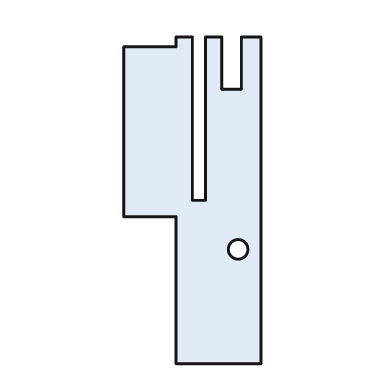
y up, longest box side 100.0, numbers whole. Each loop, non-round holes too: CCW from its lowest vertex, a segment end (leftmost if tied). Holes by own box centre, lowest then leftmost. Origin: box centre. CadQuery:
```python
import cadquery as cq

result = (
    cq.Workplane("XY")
    .moveTo(-5.0, -50.0)
    .lineTo(21.0, -50.0)
    .lineTo(21.0, 50.0)
    .lineTo(15.0, 50.0)
    .lineTo(15.0, 34.0)
    .lineTo(9.0, 34.0)
    .lineTo(9.0, 50.0)
    .lineTo(4.0, 50.0)
    .lineTo(4.0, 0.0)
    .lineTo(0.0, 0.0)
    .lineTo(0.0, 50.0)
    .lineTo(-5.0, 50.0)
    .lineTo(-5.0, 47.0)
    .lineTo(-21.0, 47.0)
    .lineTo(-21.0, -5.0)
    .lineTo(-5.0, -5.0)
    .close()
    .moveTo(14.0, -15.0)
    .circle(3.0)
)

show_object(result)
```